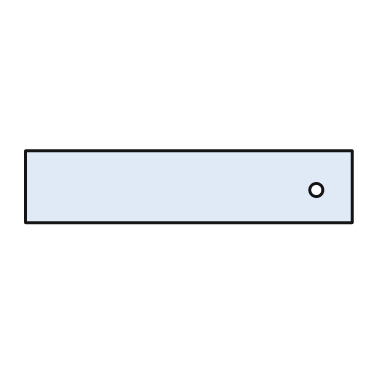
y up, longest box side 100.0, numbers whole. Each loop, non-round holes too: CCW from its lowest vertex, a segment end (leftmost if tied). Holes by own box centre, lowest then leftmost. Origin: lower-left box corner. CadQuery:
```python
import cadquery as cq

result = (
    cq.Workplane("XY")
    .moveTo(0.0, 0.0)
    .lineTo(100.0, 0.0)
    .lineTo(100.0, 22.0)
    .lineTo(0.0, 22.0)
    .close()
    .moveTo(89.0, 10.0)
    .circle(2.0)
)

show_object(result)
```